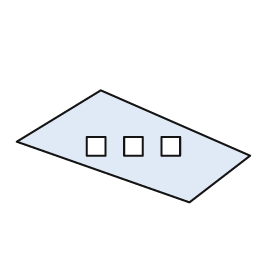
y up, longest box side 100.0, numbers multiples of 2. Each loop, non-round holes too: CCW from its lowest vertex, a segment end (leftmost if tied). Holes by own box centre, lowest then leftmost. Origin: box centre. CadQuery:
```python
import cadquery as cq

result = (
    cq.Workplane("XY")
    .moveTo(24.0, -24.0)
    .lineTo(50.0, -4.0)
    .lineTo(-14.0, 24.0)
    .lineTo(-50.0, 2.0)
    .close()
    .moveTo(-20.0, -4.0)
    .lineTo(-12.0, -4.0)
    .lineTo(-12.0, 4.0)
    .lineTo(-20.0, 4.0)
    .close()
    .moveTo(-4.0, -4.0)
    .lineTo(4.0, -4.0)
    .lineTo(4.0, 4.0)
    .lineTo(-4.0, 4.0)
    .close()
    .moveTo(12.0, -4.0)
    .lineTo(20.0, -4.0)
    .lineTo(20.0, 4.0)
    .lineTo(12.0, 4.0)
    .close()
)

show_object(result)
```